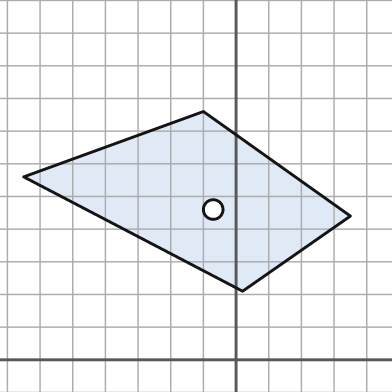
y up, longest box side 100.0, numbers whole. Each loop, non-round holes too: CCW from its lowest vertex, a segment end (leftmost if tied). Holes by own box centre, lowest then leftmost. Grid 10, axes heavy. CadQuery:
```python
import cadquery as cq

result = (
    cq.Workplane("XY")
    .moveTo(2.0, 21.0)
    .lineTo(35.0, 44.0)
    .lineTo(-10.0, 76.0)
    .lineTo(-65.0, 56.0)
    .close()
    .moveTo(-7.0, 46.0)
    .circle(3.0)
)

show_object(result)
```